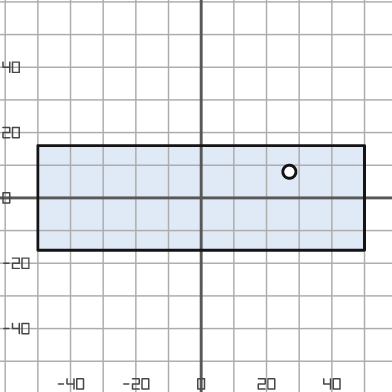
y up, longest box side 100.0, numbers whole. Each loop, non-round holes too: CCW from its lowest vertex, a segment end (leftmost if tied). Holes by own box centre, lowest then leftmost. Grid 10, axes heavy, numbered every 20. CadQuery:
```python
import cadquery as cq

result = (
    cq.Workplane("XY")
    .moveTo(-50.0, -16.0)
    .lineTo(50.0, -16.0)
    .lineTo(50.0, 16.0)
    .lineTo(-50.0, 16.0)
    .close()
    .moveTo(27.0, 8.0)
    .circle(2.0)
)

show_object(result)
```